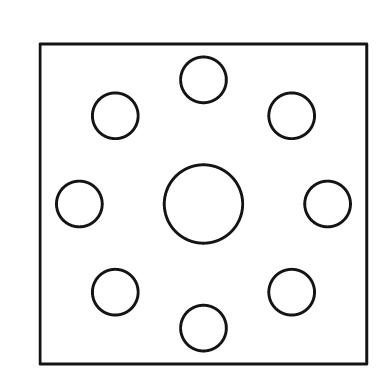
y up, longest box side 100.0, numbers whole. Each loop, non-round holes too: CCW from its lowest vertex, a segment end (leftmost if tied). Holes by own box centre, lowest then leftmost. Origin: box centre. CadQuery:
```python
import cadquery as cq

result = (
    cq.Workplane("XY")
    .moveTo(-50.0, -49.0)
    .lineTo(50.0, -49.0)
    .lineTo(50.0, 49.0)
    .lineTo(-50.0, 49.0)
    .close()
    .moveTo(0.0, -38.0)
    .circle(7.0)
    .moveTo(-27.0, -27.0)
    .circle(7.0)
    .moveTo(27.0, -27.0)
    .circle(7.0)
    .moveTo(-38.0, 0.0)
    .circle(7.0)
    .moveTo(0.0, 0.0)
    .circle(12.0)
    .moveTo(38.0, 0.0)
    .circle(7.0)
    .moveTo(-27.0, 27.0)
    .circle(7.0)
    .moveTo(27.0, 27.0)
    .circle(7.0)
    .moveTo(0.0, 38.0)
    .circle(7.0)
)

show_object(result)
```